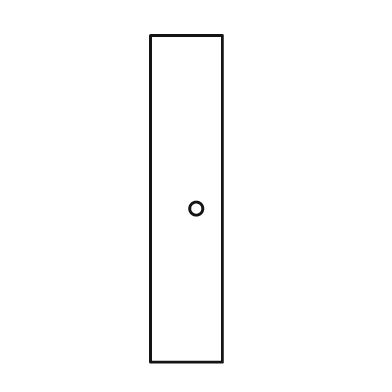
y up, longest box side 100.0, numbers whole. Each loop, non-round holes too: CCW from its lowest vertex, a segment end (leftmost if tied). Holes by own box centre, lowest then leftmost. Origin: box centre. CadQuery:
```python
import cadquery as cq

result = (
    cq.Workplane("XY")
    .moveTo(-11.0, -50.0)
    .lineTo(11.0, -50.0)
    .lineTo(11.0, 50.0)
    .lineTo(-11.0, 50.0)
    .close()
    .moveTo(3.0, -3.0)
    .circle(2.0)
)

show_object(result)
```